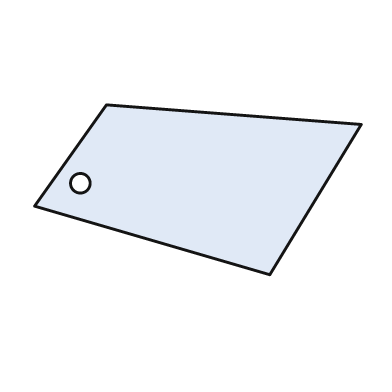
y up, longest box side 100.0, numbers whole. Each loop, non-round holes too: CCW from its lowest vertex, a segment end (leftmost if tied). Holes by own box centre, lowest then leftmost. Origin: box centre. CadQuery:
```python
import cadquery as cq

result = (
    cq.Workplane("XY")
    .moveTo(22.0, -26.0)
    .lineTo(50.0, 20.0)
    .lineTo(-28.0, 26.0)
    .lineTo(-50.0, -5.0)
    .close()
    .moveTo(-36.0, 2.0)
    .circle(3.0)
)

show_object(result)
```